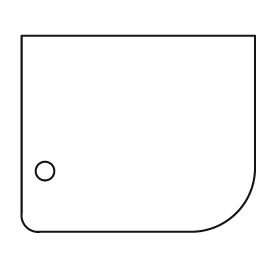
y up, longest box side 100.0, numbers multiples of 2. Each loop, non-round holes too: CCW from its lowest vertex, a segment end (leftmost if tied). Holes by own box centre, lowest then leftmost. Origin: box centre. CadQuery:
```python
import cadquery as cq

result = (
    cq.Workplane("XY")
    .moveTo(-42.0, -42.0)
    .lineTo(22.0, -42.0)
    .threePointArc((42.0, -34.0), (50.0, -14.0))
    .lineTo(50.0, 42.0)
    .lineTo(-50.0, 42.0)
    .lineTo(-50.0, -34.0)
    .threePointArc((-48.0, -40.0), (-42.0, -42.0))
    .close()
    .moveTo(-40.0, -16.0)
    .circle(4.0)
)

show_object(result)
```